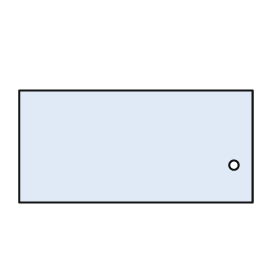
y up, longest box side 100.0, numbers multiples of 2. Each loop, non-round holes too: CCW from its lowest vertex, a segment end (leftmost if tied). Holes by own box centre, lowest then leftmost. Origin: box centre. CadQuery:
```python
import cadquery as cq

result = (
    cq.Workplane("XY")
    .moveTo(-50.0, -24.0)
    .lineTo(50.0, -24.0)
    .lineTo(50.0, 24.0)
    .lineTo(-50.0, 24.0)
    .close()
    .moveTo(42.0, -8.0)
    .circle(2.0)
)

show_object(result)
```